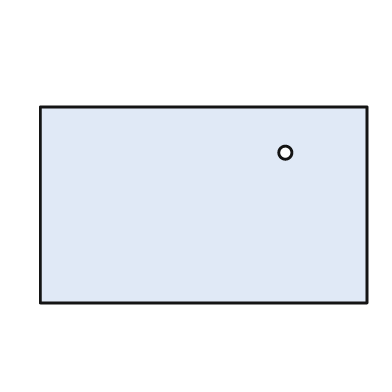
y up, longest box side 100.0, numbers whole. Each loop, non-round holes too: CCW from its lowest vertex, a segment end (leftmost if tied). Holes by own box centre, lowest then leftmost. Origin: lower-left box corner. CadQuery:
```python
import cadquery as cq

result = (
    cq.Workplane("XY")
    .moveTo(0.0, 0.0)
    .lineTo(100.0, 0.0)
    .lineTo(100.0, 60.0)
    .lineTo(0.0, 60.0)
    .close()
    .moveTo(75.0, 46.0)
    .circle(2.0)
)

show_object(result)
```